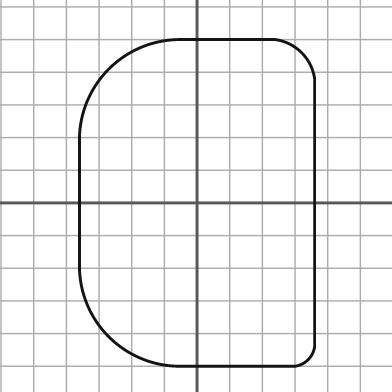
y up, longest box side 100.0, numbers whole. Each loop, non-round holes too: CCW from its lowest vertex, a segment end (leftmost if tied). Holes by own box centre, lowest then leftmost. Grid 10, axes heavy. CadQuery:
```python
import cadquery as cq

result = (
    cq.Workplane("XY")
    .moveTo(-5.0, -50.0)
    .lineTo(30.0, -50.0)
    .threePointArc((34.0, -48.0), (36.0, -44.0))
    .lineTo(36.0, 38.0)
    .threePointArc((32.0, 46.0), (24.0, 50.0))
    .lineTo(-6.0, 50.0)
    .threePointArc((-27.0, 41.0), (-36.0, 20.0))
    .lineTo(-36.0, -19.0)
    .threePointArc((-27.0, -41.0), (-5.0, -50.0))
    .close()
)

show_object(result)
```